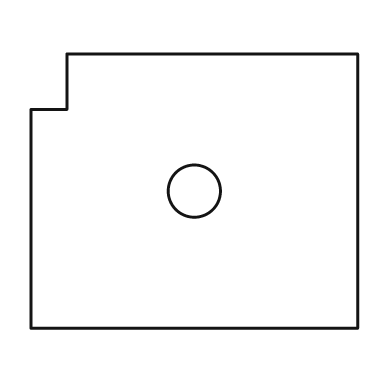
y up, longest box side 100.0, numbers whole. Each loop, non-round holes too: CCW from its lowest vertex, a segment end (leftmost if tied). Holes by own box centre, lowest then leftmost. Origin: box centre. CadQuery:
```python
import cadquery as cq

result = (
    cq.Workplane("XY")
    .moveTo(-50.0, -42.0)
    .lineTo(50.0, -42.0)
    .lineTo(50.0, 42.0)
    .lineTo(-39.0, 42.0)
    .lineTo(-39.0, 25.0)
    .lineTo(-50.0, 25.0)
    .close()
    .moveTo(0.0, 0.0)
    .circle(8.0)
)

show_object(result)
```